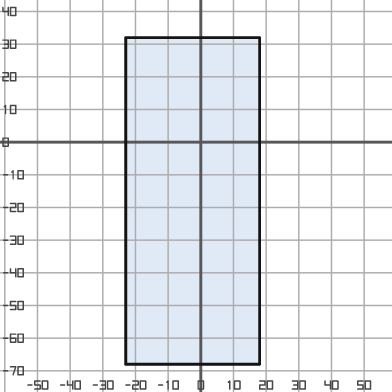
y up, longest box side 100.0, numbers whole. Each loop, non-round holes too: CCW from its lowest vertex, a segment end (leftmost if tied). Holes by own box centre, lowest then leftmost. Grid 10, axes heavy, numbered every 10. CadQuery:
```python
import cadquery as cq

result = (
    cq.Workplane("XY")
    .moveTo(-23.0, -68.0)
    .lineTo(18.0, -68.0)
    .lineTo(18.0, 32.0)
    .lineTo(-23.0, 32.0)
    .close()
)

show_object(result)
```